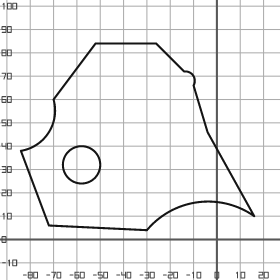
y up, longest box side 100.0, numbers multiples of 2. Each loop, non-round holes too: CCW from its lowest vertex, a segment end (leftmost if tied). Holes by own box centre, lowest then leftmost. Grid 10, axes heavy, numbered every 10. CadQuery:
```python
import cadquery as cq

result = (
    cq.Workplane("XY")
    .moveTo(-30.0, 4.0)
    .threePointArc((-8.0, 16.0), (16.0, 10.0))
    .lineTo(-4.0, 46.0)
    .lineTo(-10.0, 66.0)
    .threePointArc((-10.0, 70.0), (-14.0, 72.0))
    .lineTo(-26.0, 84.0)
    .lineTo(-52.0, 84.0)
    .lineTo(-70.0, 60.0)
    .threePointArc((-72.0, 46.0), (-84.0, 38.0))
    .lineTo(-72.0, 6.0)
    .close()
    .moveTo(-58.0, 32.0)
    .circle(8.0)
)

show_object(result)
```